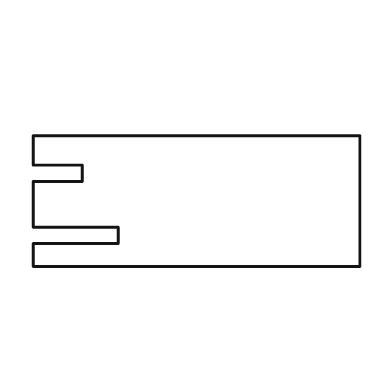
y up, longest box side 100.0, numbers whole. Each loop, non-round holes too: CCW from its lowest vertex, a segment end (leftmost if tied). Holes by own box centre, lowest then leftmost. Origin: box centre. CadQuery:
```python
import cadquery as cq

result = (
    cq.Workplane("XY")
    .moveTo(-50.0, -20.0)
    .lineTo(50.0, -20.0)
    .lineTo(50.0, 20.0)
    .lineTo(-50.0, 20.0)
    .lineTo(-50.0, 11.0)
    .lineTo(-35.0, 11.0)
    .lineTo(-35.0, 6.0)
    .lineTo(-50.0, 6.0)
    .lineTo(-50.0, -8.0)
    .lineTo(-24.0, -8.0)
    .lineTo(-24.0, -13.0)
    .lineTo(-50.0, -13.0)
    .close()
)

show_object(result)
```